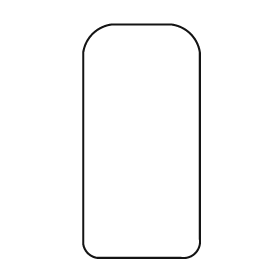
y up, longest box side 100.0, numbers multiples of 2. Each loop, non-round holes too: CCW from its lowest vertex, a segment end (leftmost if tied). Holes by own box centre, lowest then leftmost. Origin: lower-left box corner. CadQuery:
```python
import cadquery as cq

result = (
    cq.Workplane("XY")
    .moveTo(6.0, 0.0)
    .lineTo(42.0, 0.0)
    .threePointArc((48.0, 2.0), (50.0, 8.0))
    .lineTo(50.0, 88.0)
    .threePointArc((46.0, 96.0), (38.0, 100.0))
    .lineTo(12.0, 100.0)
    .threePointArc((4.0, 96.0), (0.0, 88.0))
    .lineTo(0.0, 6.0)
    .threePointArc((2.0, 2.0), (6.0, 0.0))
    .close()
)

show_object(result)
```